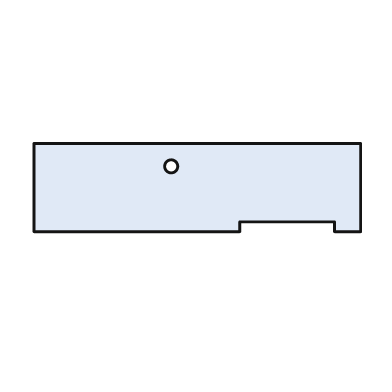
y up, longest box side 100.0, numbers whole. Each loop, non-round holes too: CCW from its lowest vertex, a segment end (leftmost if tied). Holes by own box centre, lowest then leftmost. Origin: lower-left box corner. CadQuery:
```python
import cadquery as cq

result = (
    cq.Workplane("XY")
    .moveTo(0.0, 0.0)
    .lineTo(63.0, 0.0)
    .lineTo(63.0, 3.0)
    .lineTo(92.0, 3.0)
    .lineTo(92.0, 0.0)
    .lineTo(100.0, 0.0)
    .lineTo(100.0, 27.0)
    .lineTo(0.0, 27.0)
    .close()
    .moveTo(42.0, 20.0)
    .circle(2.0)
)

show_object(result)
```